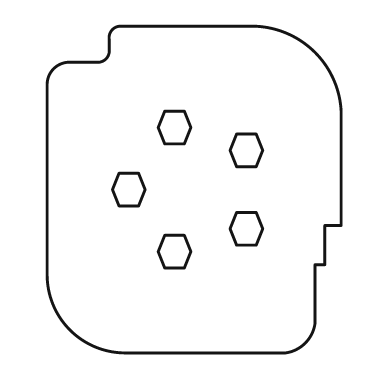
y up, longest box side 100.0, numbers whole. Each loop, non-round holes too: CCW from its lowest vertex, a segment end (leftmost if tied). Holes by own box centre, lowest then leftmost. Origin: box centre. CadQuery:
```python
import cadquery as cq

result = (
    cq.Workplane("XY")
    .moveTo(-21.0, -50.0)
    .lineTo(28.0, -50.0)
    .threePointArc((34.0, -47.0), (37.0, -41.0))
    .lineTo(37.0, -23.0)
    .lineTo(40.0, -23.0)
    .lineTo(40.0, -11.0)
    .lineTo(45.0, -11.0)
    .lineTo(45.0, 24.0)
    .threePointArc((37.0, 42.0), (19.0, 50.0))
    .lineTo(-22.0, 50.0)
    .threePointArc((-25.0, 49.0), (-26.0, 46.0))
    .lineTo(-26.0, 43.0)
    .threePointArc((-27.0, 40.0), (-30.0, 39.0))
    .lineTo(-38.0, 39.0)
    .threePointArc((-43.0, 37.0), (-45.0, 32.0))
    .lineTo(-45.0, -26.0)
    .threePointArc((-38.0, -43.0), (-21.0, -50.0))
    .close()
    .moveTo(-9.0, -24.0)
    .lineTo(-3.0, -24.0)
    .lineTo(-1.0, -19.0)
    .lineTo(-3.0, -14.0)
    .lineTo(-9.0, -14.0)
    .lineTo(-11.0, -19.0)
    .close()
    .moveTo(13.0, -17.0)
    .lineTo(19.0, -17.0)
    .lineTo(21.0, -12.0)
    .lineTo(19.0, -7.0)
    .lineTo(13.0, -7.0)
    .lineTo(11.0, -12.0)
    .close()
    .moveTo(-23.0, -5.0)
    .lineTo(-17.0, -5.0)
    .lineTo(-15.0, 0.0)
    .lineTo(-17.0, 5.0)
    .lineTo(-23.0, 5.0)
    .lineTo(-25.0, 0.0)
    .close()
    .moveTo(13.0, 7.0)
    .lineTo(19.0, 7.0)
    .lineTo(21.0, 12.0)
    .lineTo(19.0, 17.0)
    .lineTo(13.0, 17.0)
    .lineTo(11.0, 12.0)
    .close()
    .moveTo(-9.0, 14.0)
    .lineTo(-3.0, 14.0)
    .lineTo(-1.0, 19.0)
    .lineTo(-3.0, 24.0)
    .lineTo(-9.0, 24.0)
    .lineTo(-11.0, 19.0)
    .close()
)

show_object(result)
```